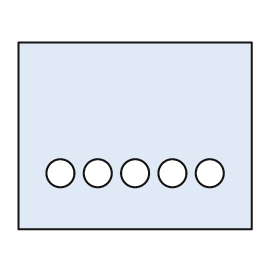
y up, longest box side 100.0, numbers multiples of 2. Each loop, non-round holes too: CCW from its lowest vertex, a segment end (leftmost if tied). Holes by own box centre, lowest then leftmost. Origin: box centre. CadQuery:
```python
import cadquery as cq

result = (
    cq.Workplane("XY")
    .moveTo(-50.0, -40.0)
    .lineTo(50.0, -40.0)
    .lineTo(50.0, 40.0)
    .lineTo(-50.0, 40.0)
    .close()
    .moveTo(-32.0, -16.0)
    .circle(6.0)
    .moveTo(-16.0, -16.0)
    .circle(6.0)
    .moveTo(0.0, -16.0)
    .circle(6.0)
    .moveTo(16.0, -16.0)
    .circle(6.0)
    .moveTo(32.0, -16.0)
    .circle(6.0)
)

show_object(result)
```